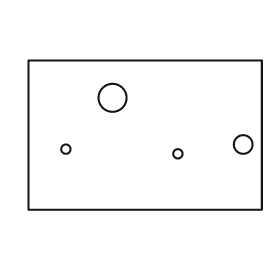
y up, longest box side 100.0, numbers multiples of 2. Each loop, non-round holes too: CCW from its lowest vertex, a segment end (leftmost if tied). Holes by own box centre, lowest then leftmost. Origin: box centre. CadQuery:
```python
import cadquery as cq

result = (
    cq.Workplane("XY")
    .moveTo(-50.0, -32.0)
    .lineTo(50.0, -32.0)
    .lineTo(50.0, 32.0)
    .lineTo(-50.0, 32.0)
    .close()
    .moveTo(14.0, -8.0)
    .circle(2.0)
    .moveTo(-34.0, -6.0)
    .circle(2.0)
    .moveTo(42.0, -4.0)
    .circle(4.0)
    .moveTo(-14.0, 16.0)
    .circle(6.0)
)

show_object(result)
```